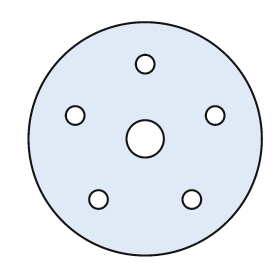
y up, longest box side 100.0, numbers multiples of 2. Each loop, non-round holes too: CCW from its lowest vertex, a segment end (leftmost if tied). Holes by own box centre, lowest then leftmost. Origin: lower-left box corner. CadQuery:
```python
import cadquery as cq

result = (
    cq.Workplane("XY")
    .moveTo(50.0, 50.0)
    .circle(50.0)
    .moveTo(30.0, 24.0)
    .circle(4.0)
    .moveTo(70.0, 24.0)
    .circle(4.0)
    .moveTo(50.0, 50.0)
    .circle(8.0)
    .moveTo(20.0, 60.0)
    .circle(4.0)
    .moveTo(80.0, 60.0)
    .circle(4.0)
    .moveTo(50.0, 82.0)
    .circle(4.0)
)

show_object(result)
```